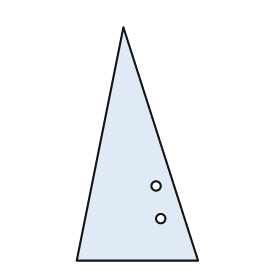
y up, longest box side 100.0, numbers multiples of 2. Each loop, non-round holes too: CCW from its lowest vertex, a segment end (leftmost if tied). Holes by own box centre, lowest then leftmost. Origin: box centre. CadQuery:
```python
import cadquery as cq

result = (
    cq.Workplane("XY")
    .moveTo(-26.0, -50.0)
    .lineTo(26.0, -50.0)
    .lineTo(-6.0, 50.0)
    .close()
    .moveTo(10.0, -32.0)
    .circle(2.0)
    .moveTo(8.0, -18.0)
    .circle(2.0)
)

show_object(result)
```